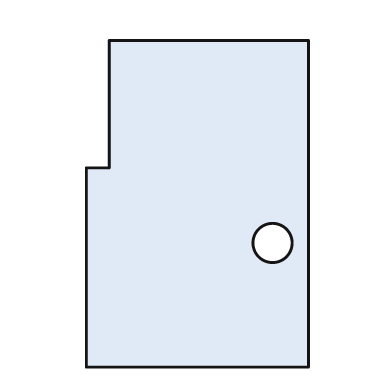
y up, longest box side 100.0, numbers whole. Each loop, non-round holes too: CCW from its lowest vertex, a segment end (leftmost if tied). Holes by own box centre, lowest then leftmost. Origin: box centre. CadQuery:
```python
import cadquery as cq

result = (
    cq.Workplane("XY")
    .moveTo(-34.0, -50.0)
    .lineTo(34.0, -50.0)
    .lineTo(34.0, 50.0)
    .lineTo(-27.0, 50.0)
    .lineTo(-27.0, 11.0)
    .lineTo(-34.0, 11.0)
    .close()
    .moveTo(23.0, -12.0)
    .circle(6.0)
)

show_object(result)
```